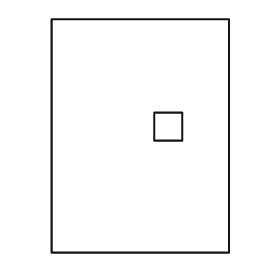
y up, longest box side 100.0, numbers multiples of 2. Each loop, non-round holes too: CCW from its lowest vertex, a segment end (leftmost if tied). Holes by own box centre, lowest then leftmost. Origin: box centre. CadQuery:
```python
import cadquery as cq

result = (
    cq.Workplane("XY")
    .moveTo(-38.0, -50.0)
    .lineTo(38.0, -50.0)
    .lineTo(38.0, 50.0)
    .lineTo(-38.0, 50.0)
    .close()
    .moveTo(6.0, -2.0)
    .lineTo(18.0, -2.0)
    .lineTo(18.0, 10.0)
    .lineTo(6.0, 10.0)
    .close()
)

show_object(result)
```